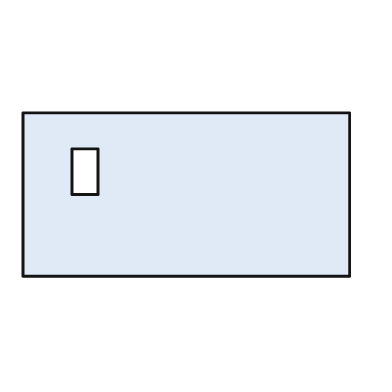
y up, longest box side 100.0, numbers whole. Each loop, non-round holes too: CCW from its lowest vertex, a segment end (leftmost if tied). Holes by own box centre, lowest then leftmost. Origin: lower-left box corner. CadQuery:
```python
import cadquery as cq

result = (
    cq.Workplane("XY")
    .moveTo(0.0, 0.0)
    .lineTo(100.0, 0.0)
    .lineTo(100.0, 50.0)
    .lineTo(0.0, 50.0)
    .close()
    .moveTo(15.0, 25.0)
    .lineTo(23.0, 25.0)
    .lineTo(23.0, 39.0)
    .lineTo(15.0, 39.0)
    .close()
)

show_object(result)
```